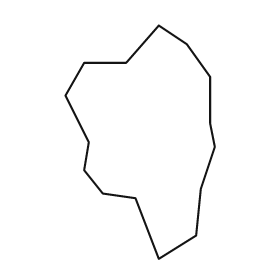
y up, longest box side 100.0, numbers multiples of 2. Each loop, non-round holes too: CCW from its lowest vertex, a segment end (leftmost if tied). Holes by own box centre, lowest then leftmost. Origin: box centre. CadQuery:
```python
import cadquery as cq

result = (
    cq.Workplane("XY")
    .moveTo(8.0, -50.0)
    .lineTo(24.0, -40.0)
    .lineTo(26.0, -20.0)
    .lineTo(32.0, -2.0)
    .lineTo(30.0, 8.0)
    .lineTo(30.0, 28.0)
    .lineTo(20.0, 42.0)
    .lineTo(8.0, 50.0)
    .lineTo(-6.0, 34.0)
    .lineTo(-24.0, 34.0)
    .lineTo(-32.0, 20.0)
    .lineTo(-22.0, 0.0)
    .lineTo(-24.0, -12.0)
    .lineTo(-16.0, -22.0)
    .lineTo(-2.0, -24.0)
    .close()
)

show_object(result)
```